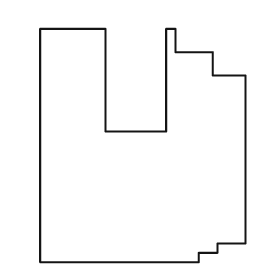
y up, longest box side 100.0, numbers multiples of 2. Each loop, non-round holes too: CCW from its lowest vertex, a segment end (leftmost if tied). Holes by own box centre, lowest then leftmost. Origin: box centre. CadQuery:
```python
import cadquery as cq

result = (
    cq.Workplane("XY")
    .moveTo(-44.0, -50.0)
    .lineTo(24.0, -50.0)
    .lineTo(24.0, -46.0)
    .lineTo(32.0, -46.0)
    .lineTo(32.0, -42.0)
    .lineTo(44.0, -42.0)
    .lineTo(44.0, 30.0)
    .lineTo(30.0, 30.0)
    .lineTo(30.0, 40.0)
    .lineTo(14.0, 40.0)
    .lineTo(14.0, 50.0)
    .lineTo(10.0, 50.0)
    .lineTo(10.0, 6.0)
    .lineTo(-16.0, 6.0)
    .lineTo(-16.0, 50.0)
    .lineTo(-44.0, 50.0)
    .close()
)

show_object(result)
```